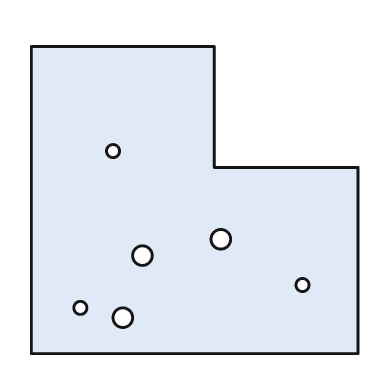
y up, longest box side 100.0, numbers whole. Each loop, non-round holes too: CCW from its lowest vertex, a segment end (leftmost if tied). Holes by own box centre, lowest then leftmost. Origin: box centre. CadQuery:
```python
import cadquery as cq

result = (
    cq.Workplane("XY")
    .moveTo(-50.0, -47.0)
    .lineTo(50.0, -47.0)
    .lineTo(50.0, 10.0)
    .lineTo(6.0, 10.0)
    .lineTo(6.0, 47.0)
    .lineTo(-50.0, 47.0)
    .close()
    .moveTo(-22.0, -36.0)
    .circle(3.0)
    .moveTo(-35.0, -33.0)
    .circle(2.0)
    .moveTo(33.0, -26.0)
    .circle(2.0)
    .moveTo(-16.0, -17.0)
    .circle(3.0)
    .moveTo(8.0, -12.0)
    .circle(3.0)
    .moveTo(-25.0, 15.0)
    .circle(2.0)
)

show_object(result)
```